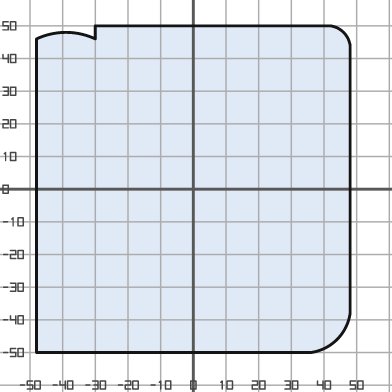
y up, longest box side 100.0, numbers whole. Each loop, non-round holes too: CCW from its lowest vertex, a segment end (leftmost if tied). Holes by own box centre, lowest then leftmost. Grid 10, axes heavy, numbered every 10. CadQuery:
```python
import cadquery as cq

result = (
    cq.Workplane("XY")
    .moveTo(-48.0, -50.0)
    .lineTo(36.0, -50.0)
    .threePointArc((44.0, -46.0), (48.0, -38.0))
    .lineTo(48.0, 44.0)
    .threePointArc((46.0, 48.0), (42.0, 50.0))
    .lineTo(-30.0, 50.0)
    .lineTo(-30.0, 46.0)
    .threePointArc((-39.0, 48.0), (-48.0, 46.0))
    .close()
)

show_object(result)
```